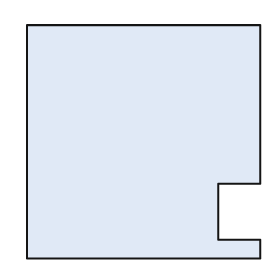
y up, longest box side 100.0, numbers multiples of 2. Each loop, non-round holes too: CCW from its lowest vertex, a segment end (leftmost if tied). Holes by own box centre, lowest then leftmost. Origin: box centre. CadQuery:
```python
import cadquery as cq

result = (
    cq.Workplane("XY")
    .moveTo(-50.0, -50.0)
    .lineTo(50.0, -50.0)
    .lineTo(50.0, -42.0)
    .lineTo(32.0, -42.0)
    .lineTo(32.0, -18.0)
    .lineTo(50.0, -18.0)
    .lineTo(50.0, 50.0)
    .lineTo(-50.0, 50.0)
    .close()
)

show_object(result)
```